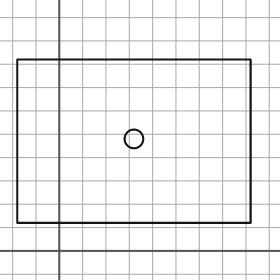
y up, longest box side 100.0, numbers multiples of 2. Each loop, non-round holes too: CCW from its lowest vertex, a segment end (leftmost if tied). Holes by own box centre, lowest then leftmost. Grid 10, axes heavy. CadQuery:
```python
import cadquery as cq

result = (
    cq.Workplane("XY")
    .moveTo(-18.0, 12.0)
    .lineTo(82.0, 12.0)
    .lineTo(82.0, 82.0)
    .lineTo(-18.0, 82.0)
    .close()
    .moveTo(32.0, 48.0)
    .circle(4.0)
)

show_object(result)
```